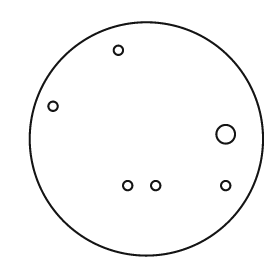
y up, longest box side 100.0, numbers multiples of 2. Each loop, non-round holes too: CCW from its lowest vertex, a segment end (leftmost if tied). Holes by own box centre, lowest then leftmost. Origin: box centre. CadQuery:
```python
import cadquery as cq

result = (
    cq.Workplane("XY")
    .moveTo(0.0, 0.0)
    .circle(50.0)
    .moveTo(-8.0, -20.0)
    .circle(2.0)
    .moveTo(4.0, -20.0)
    .circle(2.0)
    .moveTo(34.0, -20.0)
    .circle(2.0)
    .moveTo(34.0, 2.0)
    .circle(4.0)
    .moveTo(-40.0, 14.0)
    .circle(2.0)
    .moveTo(-12.0, 38.0)
    .circle(2.0)
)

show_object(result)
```